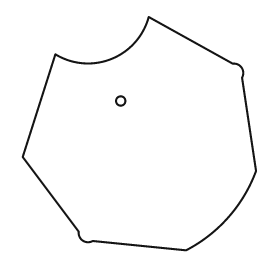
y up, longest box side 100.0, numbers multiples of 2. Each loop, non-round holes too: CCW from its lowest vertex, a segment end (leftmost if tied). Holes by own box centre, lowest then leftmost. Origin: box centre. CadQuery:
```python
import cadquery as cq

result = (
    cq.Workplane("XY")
    .moveTo(20.0, -50.0)
    .threePointArc((38.0, -36.0), (50.0, -16.0))
    .lineTo(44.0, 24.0)
    .threePointArc((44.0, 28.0), (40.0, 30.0))
    .lineTo(4.0, 50.0)
    .threePointArc((-12.0, 32.0), (-36.0, 34.0))
    .lineTo(-50.0, -10.0)
    .lineTo(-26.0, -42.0)
    .threePointArc((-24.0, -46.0), (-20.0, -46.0))
    .close()
    .moveTo(-8.0, 14.0)
    .circle(2.0)
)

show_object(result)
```